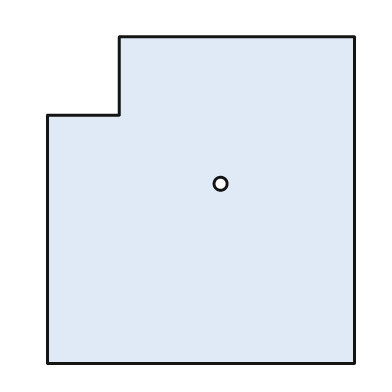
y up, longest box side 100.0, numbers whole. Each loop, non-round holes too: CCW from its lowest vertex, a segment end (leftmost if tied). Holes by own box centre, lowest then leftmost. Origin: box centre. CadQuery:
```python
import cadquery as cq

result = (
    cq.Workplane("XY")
    .moveTo(-47.0, -50.0)
    .lineTo(47.0, -50.0)
    .lineTo(47.0, 50.0)
    .lineTo(-25.0, 50.0)
    .lineTo(-25.0, 26.0)
    .lineTo(-47.0, 26.0)
    .close()
    .moveTo(6.0, 5.0)
    .circle(2.0)
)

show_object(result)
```